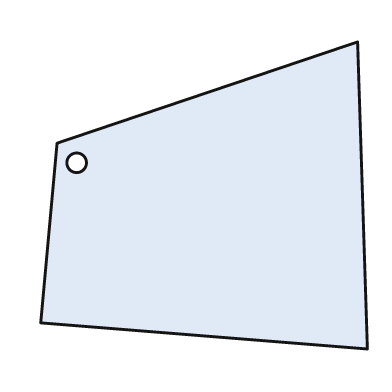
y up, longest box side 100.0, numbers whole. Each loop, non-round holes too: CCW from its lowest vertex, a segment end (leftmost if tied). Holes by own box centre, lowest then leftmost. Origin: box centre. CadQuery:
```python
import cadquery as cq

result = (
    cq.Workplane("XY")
    .moveTo(50.0, -47.0)
    .lineTo(47.0, 47.0)
    .lineTo(-45.0, 16.0)
    .lineTo(-50.0, -39.0)
    .close()
    .moveTo(-39.0, 10.0)
    .circle(3.0)
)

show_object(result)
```